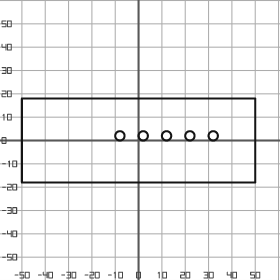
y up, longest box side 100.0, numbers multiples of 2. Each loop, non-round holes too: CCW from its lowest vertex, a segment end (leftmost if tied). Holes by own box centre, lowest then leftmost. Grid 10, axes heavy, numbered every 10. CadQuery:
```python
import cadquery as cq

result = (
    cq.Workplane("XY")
    .moveTo(-50.0, -18.0)
    .lineTo(50.0, -18.0)
    .lineTo(50.0, 18.0)
    .lineTo(-50.0, 18.0)
    .close()
    .moveTo(-8.0, 2.0)
    .circle(2.0)
    .moveTo(2.0, 2.0)
    .circle(2.0)
    .moveTo(12.0, 2.0)
    .circle(2.0)
    .moveTo(22.0, 2.0)
    .circle(2.0)
    .moveTo(32.0, 2.0)
    .circle(2.0)
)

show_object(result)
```